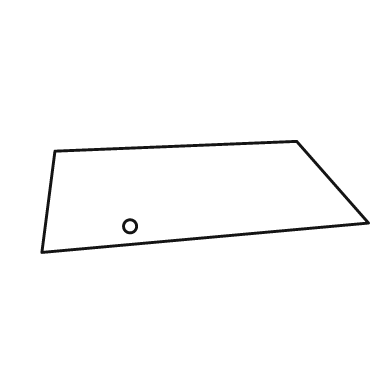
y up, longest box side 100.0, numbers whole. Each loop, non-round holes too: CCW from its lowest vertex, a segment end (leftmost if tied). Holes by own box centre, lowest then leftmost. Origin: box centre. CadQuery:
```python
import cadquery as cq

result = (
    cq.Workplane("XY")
    .moveTo(-50.0, -17.0)
    .lineTo(50.0, -8.0)
    .lineTo(28.0, 17.0)
    .lineTo(-46.0, 14.0)
    .close()
    .moveTo(-23.0, -9.0)
    .circle(2.0)
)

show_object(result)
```